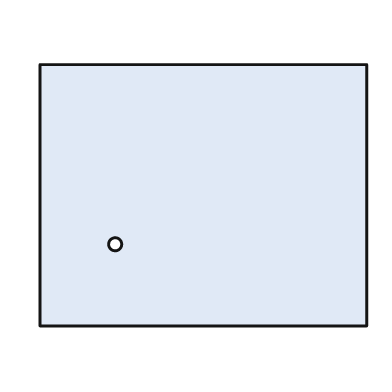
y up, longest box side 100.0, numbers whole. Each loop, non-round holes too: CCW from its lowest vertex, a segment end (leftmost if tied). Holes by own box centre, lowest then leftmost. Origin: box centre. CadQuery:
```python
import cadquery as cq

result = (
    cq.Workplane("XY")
    .moveTo(-50.0, -40.0)
    .lineTo(50.0, -40.0)
    .lineTo(50.0, 40.0)
    .lineTo(-50.0, 40.0)
    .close()
    .moveTo(-27.0, -15.0)
    .circle(2.0)
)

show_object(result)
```